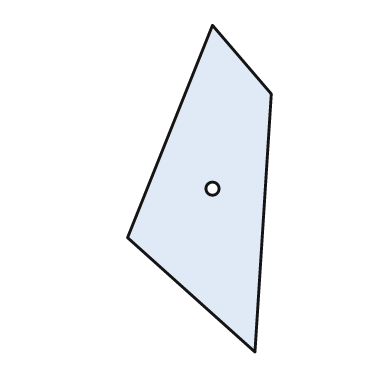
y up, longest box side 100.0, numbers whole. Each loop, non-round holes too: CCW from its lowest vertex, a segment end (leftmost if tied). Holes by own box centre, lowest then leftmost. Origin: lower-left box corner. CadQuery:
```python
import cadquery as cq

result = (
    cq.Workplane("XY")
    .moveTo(39.0, 0.0)
    .lineTo(44.0, 79.0)
    .lineTo(26.0, 100.0)
    .lineTo(0.0, 35.0)
    .close()
    .moveTo(26.0, 50.0)
    .circle(2.0)
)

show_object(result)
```